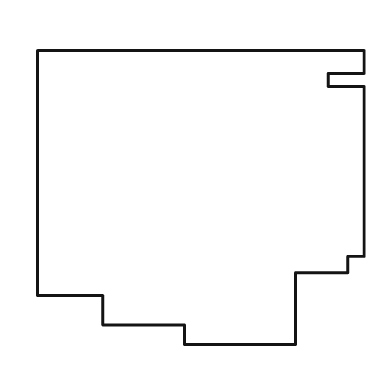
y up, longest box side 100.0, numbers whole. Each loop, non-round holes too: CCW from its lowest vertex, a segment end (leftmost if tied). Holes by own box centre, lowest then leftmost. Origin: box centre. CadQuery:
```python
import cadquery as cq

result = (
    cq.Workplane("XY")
    .moveTo(-5.0, -45.0)
    .lineTo(29.0, -45.0)
    .lineTo(29.0, -23.0)
    .lineTo(45.0, -23.0)
    .lineTo(45.0, -18.0)
    .lineTo(50.0, -18.0)
    .lineTo(50.0, 34.0)
    .lineTo(39.0, 34.0)
    .lineTo(39.0, 38.0)
    .lineTo(50.0, 38.0)
    .lineTo(50.0, 45.0)
    .lineTo(-50.0, 45.0)
    .lineTo(-50.0, -30.0)
    .lineTo(-30.0, -30.0)
    .lineTo(-30.0, -39.0)
    .lineTo(-5.0, -39.0)
    .close()
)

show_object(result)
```